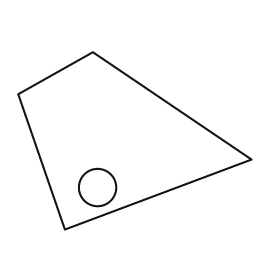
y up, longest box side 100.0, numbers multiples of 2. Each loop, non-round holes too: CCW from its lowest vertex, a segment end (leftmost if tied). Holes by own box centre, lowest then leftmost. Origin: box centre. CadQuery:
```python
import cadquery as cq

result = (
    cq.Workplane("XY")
    .moveTo(-30.0, -38.0)
    .lineTo(50.0, -8.0)
    .lineTo(-18.0, 38.0)
    .lineTo(-50.0, 20.0)
    .close()
    .moveTo(-16.0, -20.0)
    .circle(8.0)
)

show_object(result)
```